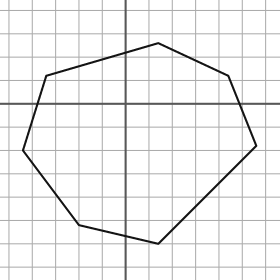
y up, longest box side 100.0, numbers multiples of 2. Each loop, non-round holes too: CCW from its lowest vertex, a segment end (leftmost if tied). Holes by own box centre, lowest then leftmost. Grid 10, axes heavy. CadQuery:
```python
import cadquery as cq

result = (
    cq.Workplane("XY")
    .moveTo(14.0, -60.0)
    .lineTo(56.0, -18.0)
    .lineTo(44.0, 12.0)
    .lineTo(14.0, 26.0)
    .lineTo(-34.0, 12.0)
    .lineTo(-44.0, -20.0)
    .lineTo(-20.0, -52.0)
    .close()
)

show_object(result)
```